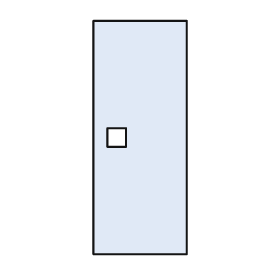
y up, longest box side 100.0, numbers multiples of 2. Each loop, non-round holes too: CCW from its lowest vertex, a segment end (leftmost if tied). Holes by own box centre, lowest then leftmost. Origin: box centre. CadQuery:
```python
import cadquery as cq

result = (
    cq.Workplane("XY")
    .moveTo(-20.0, -50.0)
    .lineTo(20.0, -50.0)
    .lineTo(20.0, 50.0)
    .lineTo(-20.0, 50.0)
    .close()
    .moveTo(-14.0, -4.0)
    .lineTo(-6.0, -4.0)
    .lineTo(-6.0, 4.0)
    .lineTo(-14.0, 4.0)
    .close()
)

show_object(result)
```